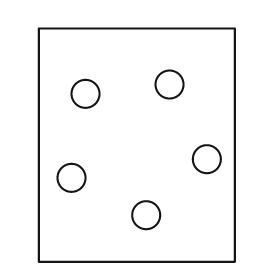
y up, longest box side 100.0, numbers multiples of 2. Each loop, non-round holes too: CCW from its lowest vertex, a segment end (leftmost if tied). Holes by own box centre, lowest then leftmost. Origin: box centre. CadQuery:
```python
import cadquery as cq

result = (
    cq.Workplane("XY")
    .moveTo(-42.0, -50.0)
    .lineTo(42.0, -50.0)
    .lineTo(42.0, 50.0)
    .lineTo(-42.0, 50.0)
    .close()
    .moveTo(4.0, -30.0)
    .circle(6.0)
    .moveTo(-28.0, -14.0)
    .circle(6.0)
    .moveTo(30.0, -6.0)
    .circle(6.0)
    .moveTo(-22.0, 22.0)
    .circle(6.0)
    .moveTo(14.0, 26.0)
    .circle(6.0)
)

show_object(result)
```